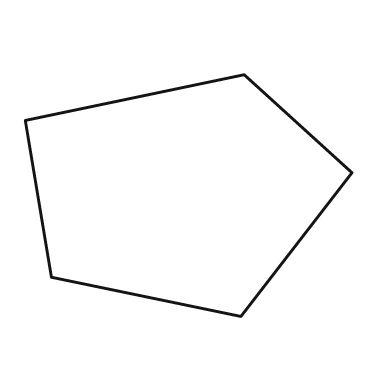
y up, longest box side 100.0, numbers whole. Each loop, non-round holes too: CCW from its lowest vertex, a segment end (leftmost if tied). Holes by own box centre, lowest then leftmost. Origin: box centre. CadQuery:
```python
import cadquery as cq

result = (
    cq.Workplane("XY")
    .moveTo(16.0, -37.0)
    .lineTo(50.0, 7.0)
    .lineTo(17.0, 37.0)
    .lineTo(-50.0, 23.0)
    .lineTo(-42.0, -25.0)
    .close()
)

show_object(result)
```